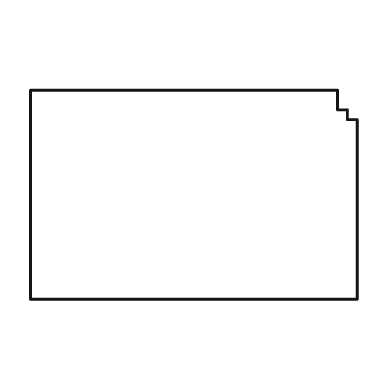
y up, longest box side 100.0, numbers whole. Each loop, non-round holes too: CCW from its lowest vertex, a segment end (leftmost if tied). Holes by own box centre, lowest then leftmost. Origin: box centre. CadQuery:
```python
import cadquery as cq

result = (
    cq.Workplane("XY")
    .moveTo(-50.0, -32.0)
    .lineTo(50.0, -32.0)
    .lineTo(50.0, 23.0)
    .lineTo(47.0, 23.0)
    .lineTo(47.0, 26.0)
    .lineTo(44.0, 26.0)
    .lineTo(44.0, 32.0)
    .lineTo(-50.0, 32.0)
    .close()
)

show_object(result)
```